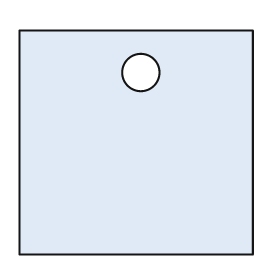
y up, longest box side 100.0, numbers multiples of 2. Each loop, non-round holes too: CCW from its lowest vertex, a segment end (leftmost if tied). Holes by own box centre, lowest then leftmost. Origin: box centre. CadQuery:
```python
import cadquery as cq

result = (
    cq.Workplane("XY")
    .moveTo(-50.0, -48.0)
    .lineTo(50.0, -48.0)
    .lineTo(50.0, 48.0)
    .lineTo(-50.0, 48.0)
    .close()
    .moveTo(2.0, 30.0)
    .circle(8.0)
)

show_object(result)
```